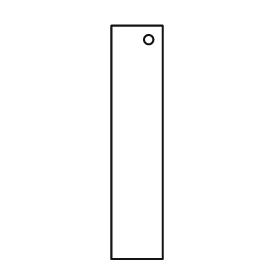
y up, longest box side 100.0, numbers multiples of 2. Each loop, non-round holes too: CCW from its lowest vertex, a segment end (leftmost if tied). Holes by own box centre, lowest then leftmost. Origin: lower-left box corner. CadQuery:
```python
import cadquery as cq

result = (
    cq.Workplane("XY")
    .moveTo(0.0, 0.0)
    .lineTo(22.0, 0.0)
    .lineTo(22.0, 100.0)
    .lineTo(0.0, 100.0)
    .close()
    .moveTo(16.0, 94.0)
    .circle(2.0)
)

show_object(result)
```